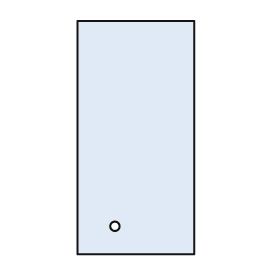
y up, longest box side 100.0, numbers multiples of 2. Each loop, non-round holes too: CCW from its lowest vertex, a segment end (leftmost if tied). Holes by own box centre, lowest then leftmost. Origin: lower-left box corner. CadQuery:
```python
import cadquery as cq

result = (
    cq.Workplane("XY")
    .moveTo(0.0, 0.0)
    .lineTo(50.0, 0.0)
    .lineTo(50.0, 100.0)
    .lineTo(0.0, 100.0)
    .close()
    .moveTo(16.0, 12.0)
    .circle(2.0)
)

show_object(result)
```